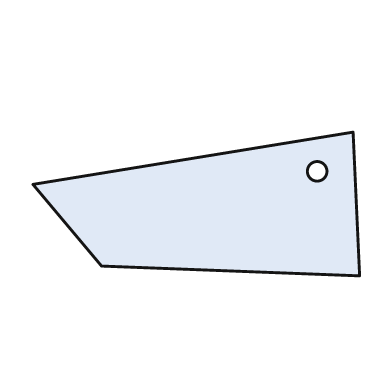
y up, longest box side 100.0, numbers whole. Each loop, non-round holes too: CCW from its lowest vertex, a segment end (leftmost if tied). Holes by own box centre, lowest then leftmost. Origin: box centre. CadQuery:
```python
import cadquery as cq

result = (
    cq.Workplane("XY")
    .moveTo(50.0, -22.0)
    .lineTo(48.0, 22.0)
    .lineTo(-50.0, 6.0)
    .lineTo(-29.0, -19.0)
    .close()
    .moveTo(37.0, 10.0)
    .circle(3.0)
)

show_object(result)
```